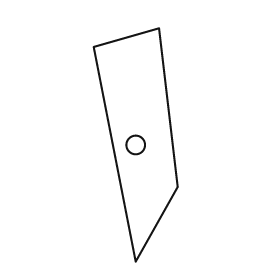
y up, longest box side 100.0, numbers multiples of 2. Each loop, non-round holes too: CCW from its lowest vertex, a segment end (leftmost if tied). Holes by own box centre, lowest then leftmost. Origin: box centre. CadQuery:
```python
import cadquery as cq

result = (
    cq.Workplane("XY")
    .moveTo(0.0, -50.0)
    .lineTo(18.0, -18.0)
    .lineTo(10.0, 50.0)
    .lineTo(-18.0, 42.0)
    .close()
    .moveTo(0.0, 0.0)
    .circle(4.0)
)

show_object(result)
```